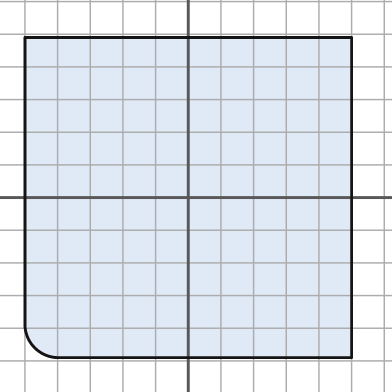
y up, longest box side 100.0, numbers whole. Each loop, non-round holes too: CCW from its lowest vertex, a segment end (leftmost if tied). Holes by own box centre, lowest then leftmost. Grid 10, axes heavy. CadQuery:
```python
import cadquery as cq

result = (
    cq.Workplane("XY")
    .moveTo(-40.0, -49.0)
    .lineTo(50.0, -49.0)
    .lineTo(50.0, 49.0)
    .lineTo(-50.0, 49.0)
    .lineTo(-50.0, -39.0)
    .threePointArc((-47.0, -46.0), (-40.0, -49.0))
    .close()
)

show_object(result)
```